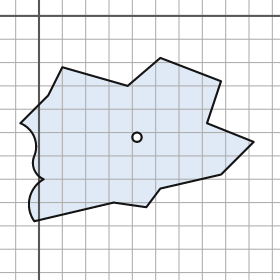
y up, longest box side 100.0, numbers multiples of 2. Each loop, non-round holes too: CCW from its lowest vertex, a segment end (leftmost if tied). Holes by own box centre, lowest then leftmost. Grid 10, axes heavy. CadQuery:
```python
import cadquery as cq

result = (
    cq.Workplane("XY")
    .moveTo(-2.0, -88.0)
    .lineTo(32.0, -80.0)
    .lineTo(46.0, -82.0)
    .lineTo(52.0, -74.0)
    .lineTo(78.0, -68.0)
    .lineTo(92.0, -54.0)
    .lineTo(72.0, -46.0)
    .lineTo(78.0, -28.0)
    .lineTo(52.0, -18.0)
    .lineTo(38.0, -30.0)
    .lineTo(10.0, -22.0)
    .lineTo(4.0, -34.0)
    .lineTo(-8.0, -46.0)
    .threePointArc((-2.0, -52.0), (-2.0, -60.0))
    .threePointArc((-2.0, -66.0), (2.0, -70.0))
    .threePointArc((-4.0, -78.0), (-2.0, -88.0))
    .close()
    .moveTo(42.0, -52.0)
    .circle(2.0)
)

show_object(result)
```